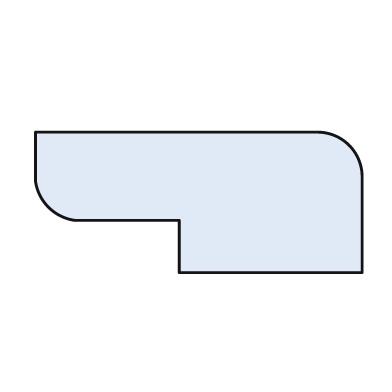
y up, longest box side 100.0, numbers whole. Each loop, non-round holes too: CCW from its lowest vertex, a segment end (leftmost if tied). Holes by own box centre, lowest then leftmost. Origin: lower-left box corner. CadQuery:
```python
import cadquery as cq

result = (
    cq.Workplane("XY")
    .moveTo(44.0, 0.0)
    .lineTo(100.0, 0.0)
    .lineTo(100.0, 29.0)
    .threePointArc((96.0, 39.0), (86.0, 43.0))
    .lineTo(0.0, 43.0)
    .lineTo(0.0, 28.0)
    .threePointArc((4.0, 20.0), (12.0, 16.0))
    .lineTo(44.0, 16.0)
    .close()
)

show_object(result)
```